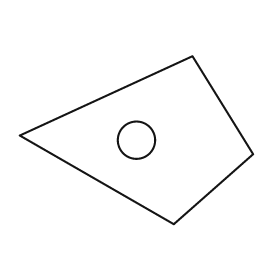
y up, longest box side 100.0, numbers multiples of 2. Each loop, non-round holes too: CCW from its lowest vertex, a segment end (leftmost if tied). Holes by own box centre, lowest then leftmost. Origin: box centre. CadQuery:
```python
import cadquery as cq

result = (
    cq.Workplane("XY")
    .moveTo(16.0, -36.0)
    .lineTo(50.0, -6.0)
    .lineTo(24.0, 36.0)
    .lineTo(-50.0, 2.0)
    .close()
    .moveTo(0.0, 0.0)
    .circle(8.0)
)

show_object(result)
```